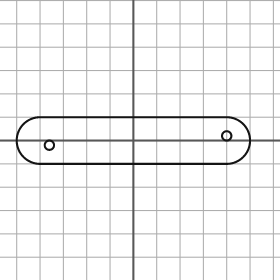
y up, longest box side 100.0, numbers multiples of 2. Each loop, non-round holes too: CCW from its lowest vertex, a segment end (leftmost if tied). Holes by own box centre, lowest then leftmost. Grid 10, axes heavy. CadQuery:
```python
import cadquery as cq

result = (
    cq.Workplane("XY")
    .moveTo(-40.0, -10.0)
    .lineTo(40.0, -10.0)
    .threePointArc((50.0, 0.0), (40.0, 10.0))
    .lineTo(-40.0, 10.0)
    .threePointArc((-50.0, 0.0), (-40.0, -10.0))
    .close()
    .moveTo(-36.0, -2.0)
    .circle(2.0)
    .moveTo(40.0, 2.0)
    .circle(2.0)
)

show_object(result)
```